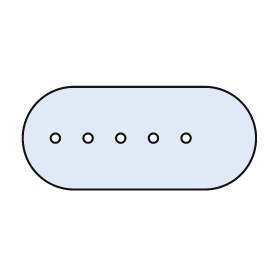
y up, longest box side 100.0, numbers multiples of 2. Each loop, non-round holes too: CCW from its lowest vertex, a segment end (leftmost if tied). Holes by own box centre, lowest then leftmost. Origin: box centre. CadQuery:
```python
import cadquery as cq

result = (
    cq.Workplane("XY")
    .moveTo(-28.0, -22.0)
    .lineTo(28.0, -22.0)
    .threePointArc((50.0, 0.0), (28.0, 22.0))
    .lineTo(-28.0, 22.0)
    .threePointArc((-50.0, 0.0), (-28.0, -22.0))
    .close()
    .moveTo(-36.0, 0.0)
    .circle(2.0)
    .moveTo(-22.0, 0.0)
    .circle(2.0)
    .moveTo(-8.0, 0.0)
    .circle(2.0)
    .moveTo(6.0, 0.0)
    .circle(2.0)
    .moveTo(20.0, 0.0)
    .circle(2.0)
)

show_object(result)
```